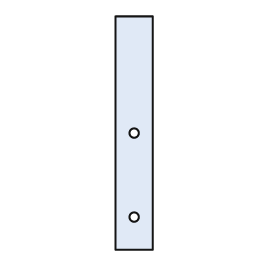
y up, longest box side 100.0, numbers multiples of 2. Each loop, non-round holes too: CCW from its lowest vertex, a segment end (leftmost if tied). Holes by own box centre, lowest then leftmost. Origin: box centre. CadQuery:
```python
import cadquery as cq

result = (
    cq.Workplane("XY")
    .moveTo(-8.0, -50.0)
    .lineTo(8.0, -50.0)
    .lineTo(8.0, 50.0)
    .lineTo(-8.0, 50.0)
    .close()
    .moveTo(0.0, -36.0)
    .circle(2.0)
    .moveTo(0.0, 0.0)
    .circle(2.0)
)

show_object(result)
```